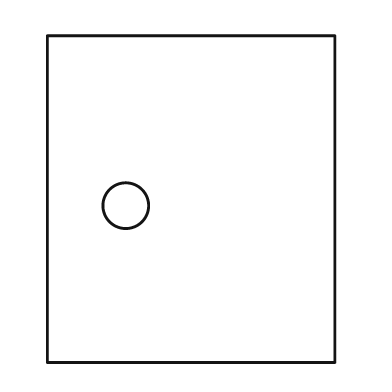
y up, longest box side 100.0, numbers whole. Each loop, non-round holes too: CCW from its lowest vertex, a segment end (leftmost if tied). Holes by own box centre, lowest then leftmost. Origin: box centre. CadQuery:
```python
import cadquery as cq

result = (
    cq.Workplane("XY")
    .moveTo(-44.0, -50.0)
    .lineTo(44.0, -50.0)
    .lineTo(44.0, 50.0)
    .lineTo(-44.0, 50.0)
    .close()
    .moveTo(-20.0, -2.0)
    .circle(7.0)
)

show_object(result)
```